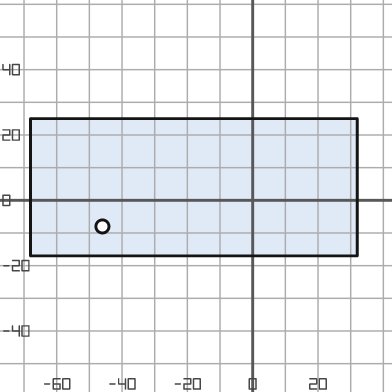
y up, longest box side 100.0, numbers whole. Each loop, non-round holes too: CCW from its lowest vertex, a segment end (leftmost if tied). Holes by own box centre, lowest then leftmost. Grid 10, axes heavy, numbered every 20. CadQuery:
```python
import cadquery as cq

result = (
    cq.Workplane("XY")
    .moveTo(-68.0, -17.0)
    .lineTo(32.0, -17.0)
    .lineTo(32.0, 25.0)
    .lineTo(-68.0, 25.0)
    .close()
    .moveTo(-46.0, -8.0)
    .circle(2.0)
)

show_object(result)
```